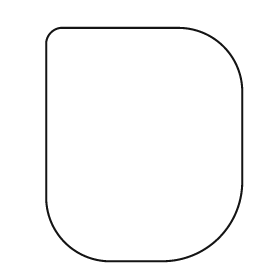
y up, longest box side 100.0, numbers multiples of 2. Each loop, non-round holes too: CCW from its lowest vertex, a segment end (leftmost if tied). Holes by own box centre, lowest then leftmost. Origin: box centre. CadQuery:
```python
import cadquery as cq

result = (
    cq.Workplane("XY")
    .moveTo(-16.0, -50.0)
    .lineTo(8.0, -50.0)
    .threePointArc((32.0, -40.0), (42.0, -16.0))
    .lineTo(42.0, 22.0)
    .threePointArc((34.0, 42.0), (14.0, 50.0))
    .lineTo(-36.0, 50.0)
    .threePointArc((-40.0, 48.0), (-42.0, 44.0))
    .lineTo(-42.0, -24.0)
    .threePointArc((-34.0, -42.0), (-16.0, -50.0))
    .close()
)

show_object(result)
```